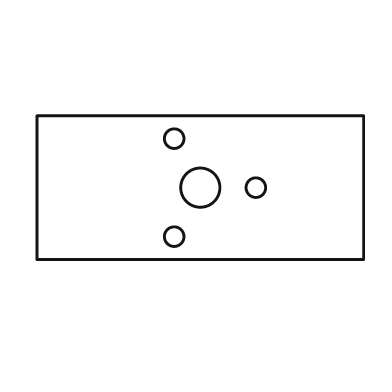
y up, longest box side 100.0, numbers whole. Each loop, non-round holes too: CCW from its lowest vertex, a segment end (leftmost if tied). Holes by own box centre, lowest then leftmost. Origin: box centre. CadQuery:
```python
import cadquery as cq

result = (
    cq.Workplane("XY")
    .moveTo(-50.0, -22.0)
    .lineTo(50.0, -22.0)
    .lineTo(50.0, 22.0)
    .lineTo(-50.0, 22.0)
    .close()
    .moveTo(-8.0, -15.0)
    .circle(3.0)
    .moveTo(0.0, 0.0)
    .circle(6.0)
    .moveTo(17.0, 0.0)
    .circle(3.0)
    .moveTo(-8.0, 15.0)
    .circle(3.0)
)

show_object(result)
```